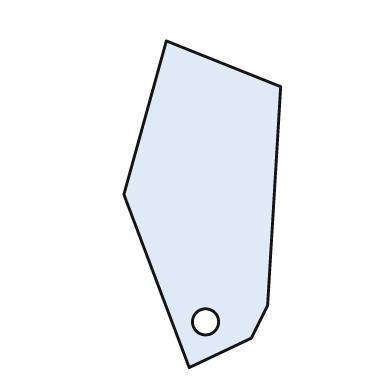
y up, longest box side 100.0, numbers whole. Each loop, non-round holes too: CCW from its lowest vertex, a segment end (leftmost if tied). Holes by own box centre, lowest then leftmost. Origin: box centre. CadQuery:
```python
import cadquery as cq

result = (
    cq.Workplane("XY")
    .moveTo(-4.0, -50.0)
    .lineTo(15.0, -41.0)
    .lineTo(20.0, -31.0)
    .lineTo(24.0, 36.0)
    .lineTo(-11.0, 50.0)
    .lineTo(-24.0, 3.0)
    .close()
    .moveTo(1.0, -36.0)
    .circle(4.0)
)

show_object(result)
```